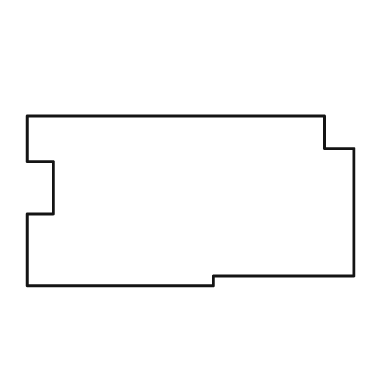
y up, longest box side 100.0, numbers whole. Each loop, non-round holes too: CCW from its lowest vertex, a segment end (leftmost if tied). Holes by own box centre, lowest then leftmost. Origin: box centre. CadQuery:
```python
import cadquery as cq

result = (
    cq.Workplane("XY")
    .moveTo(-50.0, -26.0)
    .lineTo(7.0, -26.0)
    .lineTo(7.0, -23.0)
    .lineTo(50.0, -23.0)
    .lineTo(50.0, 16.0)
    .lineTo(41.0, 16.0)
    .lineTo(41.0, 26.0)
    .lineTo(-50.0, 26.0)
    .lineTo(-50.0, 12.0)
    .lineTo(-42.0, 12.0)
    .lineTo(-42.0, -4.0)
    .lineTo(-50.0, -4.0)
    .close()
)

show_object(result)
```